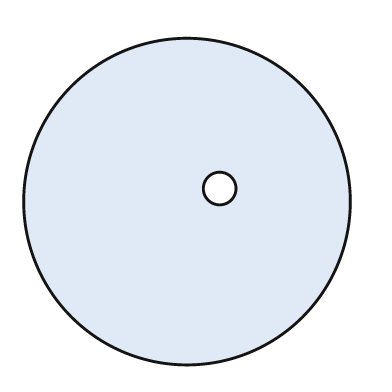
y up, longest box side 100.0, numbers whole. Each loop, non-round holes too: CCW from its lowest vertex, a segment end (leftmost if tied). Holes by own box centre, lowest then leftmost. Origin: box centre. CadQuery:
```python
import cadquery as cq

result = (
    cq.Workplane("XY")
    .moveTo(0.0, 0.0)
    .circle(50.0)
    .moveTo(10.0, 4.0)
    .circle(5.0)
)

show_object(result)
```